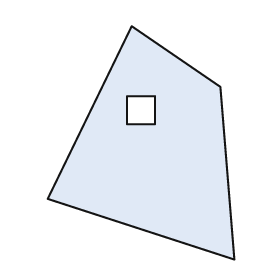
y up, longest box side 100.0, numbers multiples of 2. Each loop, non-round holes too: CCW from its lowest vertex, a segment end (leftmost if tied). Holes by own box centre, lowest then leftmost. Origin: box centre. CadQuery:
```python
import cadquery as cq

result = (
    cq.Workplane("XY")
    .moveTo(40.0, -50.0)
    .lineTo(34.0, 24.0)
    .lineTo(-4.0, 50.0)
    .lineTo(-40.0, -24.0)
    .close()
    .moveTo(-6.0, 8.0)
    .lineTo(6.0, 8.0)
    .lineTo(6.0, 20.0)
    .lineTo(-6.0, 20.0)
    .close()
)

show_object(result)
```